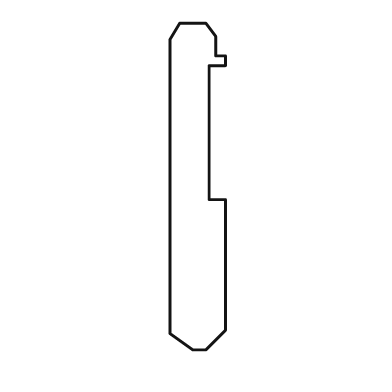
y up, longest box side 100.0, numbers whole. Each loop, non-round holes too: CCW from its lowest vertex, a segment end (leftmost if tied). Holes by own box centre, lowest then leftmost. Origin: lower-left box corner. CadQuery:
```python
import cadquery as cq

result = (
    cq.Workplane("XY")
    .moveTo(7.0, 0.0)
    .lineTo(11.0, 0.0)
    .lineTo(17.0, 6.0)
    .lineTo(17.0, 46.0)
    .lineTo(12.0, 46.0)
    .lineTo(12.0, 87.0)
    .lineTo(17.0, 87.0)
    .lineTo(17.0, 90.0)
    .lineTo(14.0, 90.0)
    .lineTo(14.0, 96.0)
    .lineTo(11.0, 100.0)
    .lineTo(3.0, 100.0)
    .lineTo(0.0, 95.0)
    .lineTo(0.0, 5.0)
    .close()
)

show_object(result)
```